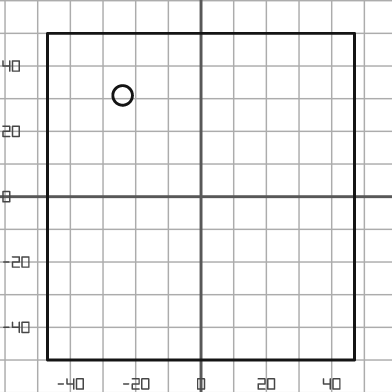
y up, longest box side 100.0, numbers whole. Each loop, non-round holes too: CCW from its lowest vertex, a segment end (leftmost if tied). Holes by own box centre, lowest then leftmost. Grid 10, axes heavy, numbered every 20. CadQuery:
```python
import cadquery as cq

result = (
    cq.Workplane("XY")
    .moveTo(-47.0, -50.0)
    .lineTo(47.0, -50.0)
    .lineTo(47.0, 50.0)
    .lineTo(-47.0, 50.0)
    .close()
    .moveTo(-24.0, 31.0)
    .circle(3.0)
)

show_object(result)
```